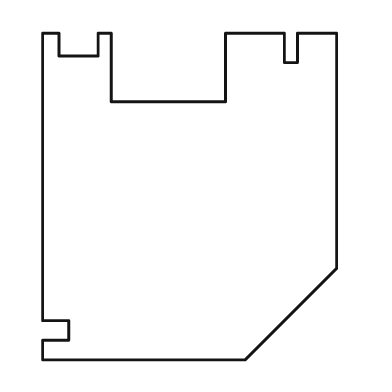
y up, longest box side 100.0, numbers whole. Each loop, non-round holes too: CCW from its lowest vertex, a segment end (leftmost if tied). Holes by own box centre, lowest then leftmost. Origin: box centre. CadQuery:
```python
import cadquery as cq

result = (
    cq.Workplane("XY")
    .moveTo(-45.0, -50.0)
    .lineTo(17.0, -50.0)
    .lineTo(45.0, -22.0)
    .lineTo(45.0, 50.0)
    .lineTo(33.0, 50.0)
    .lineTo(33.0, 41.0)
    .lineTo(29.0, 41.0)
    .lineTo(29.0, 50.0)
    .lineTo(11.0, 50.0)
    .lineTo(11.0, 29.0)
    .lineTo(-24.0, 29.0)
    .lineTo(-24.0, 50.0)
    .lineTo(-28.0, 50.0)
    .lineTo(-28.0, 43.0)
    .lineTo(-40.0, 43.0)
    .lineTo(-40.0, 50.0)
    .lineTo(-45.0, 50.0)
    .lineTo(-45.0, -38.0)
    .lineTo(-37.0, -38.0)
    .lineTo(-37.0, -44.0)
    .lineTo(-45.0, -44.0)
    .close()
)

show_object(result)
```